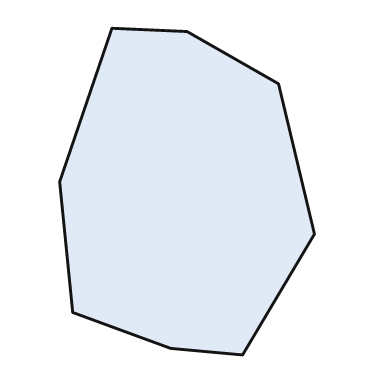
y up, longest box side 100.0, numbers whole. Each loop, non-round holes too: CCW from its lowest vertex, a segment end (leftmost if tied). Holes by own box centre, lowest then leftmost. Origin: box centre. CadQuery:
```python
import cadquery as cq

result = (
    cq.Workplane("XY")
    .moveTo(17.0, -50.0)
    .lineTo(39.0, -13.0)
    .lineTo(28.0, 33.0)
    .lineTo(0.0, 49.0)
    .lineTo(-23.0, 50.0)
    .lineTo(-39.0, 3.0)
    .lineTo(-35.0, -37.0)
    .lineTo(-5.0, -48.0)
    .close()
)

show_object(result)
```